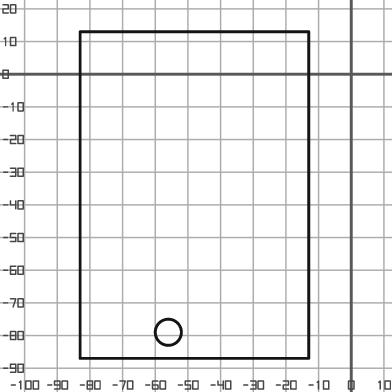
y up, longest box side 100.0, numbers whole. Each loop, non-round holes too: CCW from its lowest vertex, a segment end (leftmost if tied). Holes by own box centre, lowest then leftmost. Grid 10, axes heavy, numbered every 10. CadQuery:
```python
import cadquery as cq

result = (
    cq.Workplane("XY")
    .moveTo(-83.0, -87.0)
    .lineTo(-13.0, -87.0)
    .lineTo(-13.0, 13.0)
    .lineTo(-83.0, 13.0)
    .close()
    .moveTo(-56.0, -79.0)
    .circle(4.0)
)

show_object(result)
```